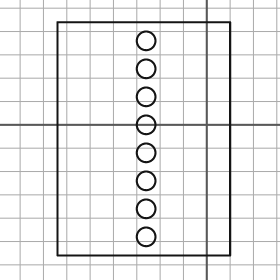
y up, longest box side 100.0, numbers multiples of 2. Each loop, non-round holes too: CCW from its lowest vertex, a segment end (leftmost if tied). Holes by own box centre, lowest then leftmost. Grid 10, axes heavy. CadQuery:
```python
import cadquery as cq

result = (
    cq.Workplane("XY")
    .moveTo(-64.0, -56.0)
    .lineTo(10.0, -56.0)
    .lineTo(10.0, 44.0)
    .lineTo(-64.0, 44.0)
    .close()
    .moveTo(-26.0, -48.0)
    .circle(4.0)
    .moveTo(-26.0, -36.0)
    .circle(4.0)
    .moveTo(-26.0, -24.0)
    .circle(4.0)
    .moveTo(-26.0, -12.0)
    .circle(4.0)
    .moveTo(-26.0, 0.0)
    .circle(4.0)
    .moveTo(-26.0, 12.0)
    .circle(4.0)
    .moveTo(-26.0, 24.0)
    .circle(4.0)
    .moveTo(-26.0, 36.0)
    .circle(4.0)
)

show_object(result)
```